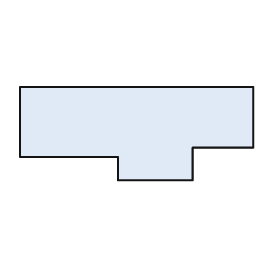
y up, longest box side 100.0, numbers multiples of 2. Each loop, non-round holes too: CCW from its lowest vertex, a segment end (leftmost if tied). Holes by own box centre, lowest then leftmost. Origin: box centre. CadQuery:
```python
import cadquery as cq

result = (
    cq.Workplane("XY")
    .moveTo(-8.0, -20.0)
    .lineTo(24.0, -20.0)
    .lineTo(24.0, -6.0)
    .lineTo(50.0, -6.0)
    .lineTo(50.0, 20.0)
    .lineTo(-50.0, 20.0)
    .lineTo(-50.0, -10.0)
    .lineTo(-8.0, -10.0)
    .close()
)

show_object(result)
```